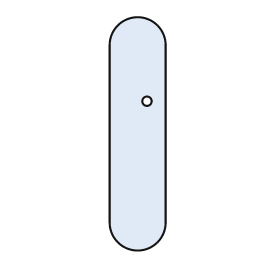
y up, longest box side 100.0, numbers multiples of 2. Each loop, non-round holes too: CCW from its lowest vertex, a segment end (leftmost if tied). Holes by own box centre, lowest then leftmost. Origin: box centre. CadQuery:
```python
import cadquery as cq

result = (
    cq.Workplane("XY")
    .moveTo(-12.0, -38.0)
    .threePointArc((0.0, -50.0), (12.0, -38.0))
    .lineTo(12.0, 38.0)
    .threePointArc((0.0, 50.0), (-12.0, 38.0))
    .close()
    .moveTo(4.0, 14.0)
    .circle(2.0)
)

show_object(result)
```